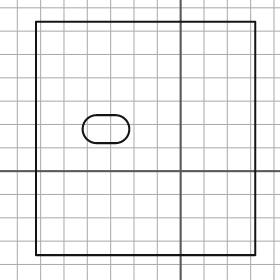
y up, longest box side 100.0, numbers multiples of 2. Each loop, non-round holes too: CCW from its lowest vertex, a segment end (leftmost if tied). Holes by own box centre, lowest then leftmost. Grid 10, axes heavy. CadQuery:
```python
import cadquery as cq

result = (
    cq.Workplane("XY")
    .moveTo(-62.0, -36.0)
    .lineTo(32.0, -36.0)
    .lineTo(32.0, 64.0)
    .lineTo(-62.0, 64.0)
    .close()
    .moveTo(-36.0, 12.0)
    .lineTo(-28.0, 12.0)
    .threePointArc((-22.0, 18.0), (-28.0, 24.0))
    .lineTo(-36.0, 24.0)
    .threePointArc((-42.0, 18.0), (-36.0, 12.0))
    .close()
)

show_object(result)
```